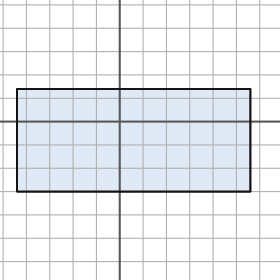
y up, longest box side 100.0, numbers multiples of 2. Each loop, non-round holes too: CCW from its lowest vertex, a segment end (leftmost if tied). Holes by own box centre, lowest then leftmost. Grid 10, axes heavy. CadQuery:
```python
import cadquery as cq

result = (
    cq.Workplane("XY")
    .moveTo(-44.0, -30.0)
    .lineTo(56.0, -30.0)
    .lineTo(56.0, 14.0)
    .lineTo(-44.0, 14.0)
    .close()
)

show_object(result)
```